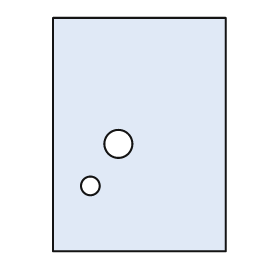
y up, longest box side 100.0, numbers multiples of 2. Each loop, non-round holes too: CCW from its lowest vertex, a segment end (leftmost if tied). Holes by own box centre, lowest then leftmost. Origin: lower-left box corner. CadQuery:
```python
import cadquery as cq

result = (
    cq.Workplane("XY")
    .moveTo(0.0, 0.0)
    .lineTo(74.0, 0.0)
    .lineTo(74.0, 100.0)
    .lineTo(0.0, 100.0)
    .close()
    .moveTo(16.0, 28.0)
    .circle(4.0)
    .moveTo(28.0, 46.0)
    .circle(6.0)
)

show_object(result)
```